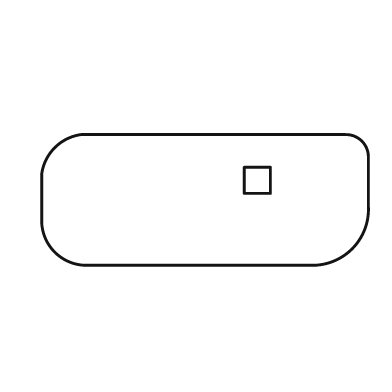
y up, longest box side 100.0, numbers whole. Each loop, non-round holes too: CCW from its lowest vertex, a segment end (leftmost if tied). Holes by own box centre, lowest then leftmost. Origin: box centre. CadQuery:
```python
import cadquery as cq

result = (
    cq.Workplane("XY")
    .moveTo(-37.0, -20.0)
    .lineTo(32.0, -20.0)
    .threePointArc((45.0, -15.0), (50.0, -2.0))
    .lineTo(50.0, 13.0)
    .threePointArc((48.0, 18.0), (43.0, 20.0))
    .lineTo(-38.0, 20.0)
    .threePointArc((-46.0, 16.0), (-50.0, 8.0))
    .lineTo(-50.0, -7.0)
    .threePointArc((-46.0, -16.0), (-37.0, -20.0))
    .close()
    .moveTo(12.0, 2.0)
    .lineTo(20.0, 2.0)
    .lineTo(20.0, 10.0)
    .lineTo(12.0, 10.0)
    .close()
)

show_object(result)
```